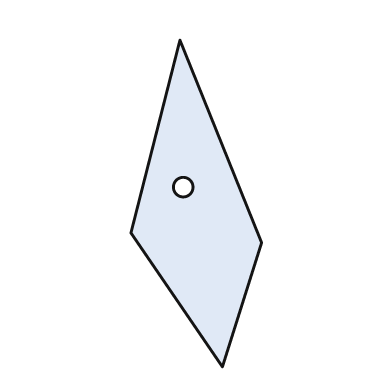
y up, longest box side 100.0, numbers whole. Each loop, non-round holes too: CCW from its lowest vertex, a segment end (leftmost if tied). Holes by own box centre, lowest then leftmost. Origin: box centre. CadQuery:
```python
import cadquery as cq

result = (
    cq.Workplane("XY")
    .moveTo(8.0, -50.0)
    .lineTo(20.0, -12.0)
    .lineTo(-5.0, 50.0)
    .lineTo(-20.0, -9.0)
    .close()
    .moveTo(-4.0, 5.0)
    .circle(3.0)
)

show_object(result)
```